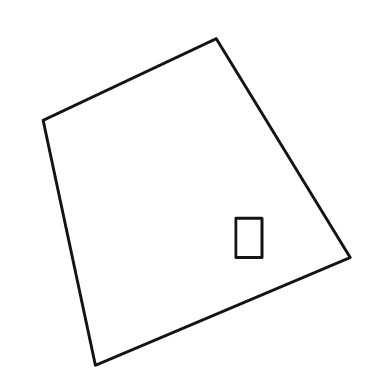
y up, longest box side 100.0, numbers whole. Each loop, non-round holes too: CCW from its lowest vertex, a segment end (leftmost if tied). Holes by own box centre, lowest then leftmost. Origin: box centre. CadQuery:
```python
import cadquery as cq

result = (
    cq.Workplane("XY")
    .moveTo(-31.0, -50.0)
    .lineTo(47.0, -17.0)
    .lineTo(6.0, 50.0)
    .lineTo(-47.0, 25.0)
    .close()
    .moveTo(12.0, -17.0)
    .lineTo(20.0, -17.0)
    .lineTo(20.0, -5.0)
    .lineTo(12.0, -5.0)
    .close()
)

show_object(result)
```